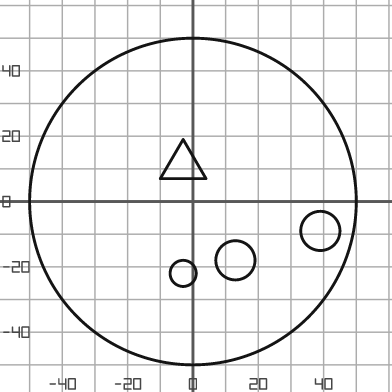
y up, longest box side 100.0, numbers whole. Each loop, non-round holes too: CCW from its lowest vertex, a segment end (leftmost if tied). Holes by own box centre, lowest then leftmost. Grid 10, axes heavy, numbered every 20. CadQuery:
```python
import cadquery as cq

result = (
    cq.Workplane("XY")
    .moveTo(0.0, 0.0)
    .circle(50.0)
    .moveTo(-3.0, -22.0)
    .circle(4.0)
    .moveTo(13.0, -18.0)
    .circle(6.0)
    .moveTo(39.0, -9.0)
    .circle(6.0)
    .moveTo(-10.0, 7.0)
    .lineTo(4.0, 7.0)
    .lineTo(-3.0, 19.0)
    .close()
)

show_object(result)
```